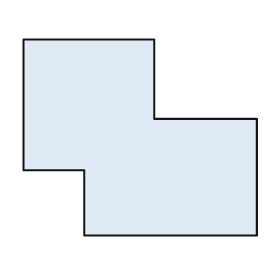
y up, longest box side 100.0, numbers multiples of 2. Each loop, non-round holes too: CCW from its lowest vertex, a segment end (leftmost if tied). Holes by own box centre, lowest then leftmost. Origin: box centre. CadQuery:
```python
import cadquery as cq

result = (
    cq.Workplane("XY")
    .moveTo(-24.0, -42.0)
    .lineTo(50.0, -42.0)
    .lineTo(50.0, 8.0)
    .lineTo(6.0, 8.0)
    .lineTo(6.0, 42.0)
    .lineTo(-50.0, 42.0)
    .lineTo(-50.0, -14.0)
    .lineTo(-24.0, -14.0)
    .close()
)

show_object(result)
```